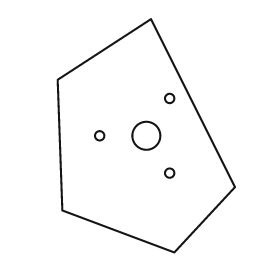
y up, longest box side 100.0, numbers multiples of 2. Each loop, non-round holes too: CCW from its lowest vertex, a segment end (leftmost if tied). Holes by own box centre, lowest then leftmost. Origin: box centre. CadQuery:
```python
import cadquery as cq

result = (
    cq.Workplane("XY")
    .moveTo(12.0, -50.0)
    .lineTo(38.0, -22.0)
    .lineTo(2.0, 50.0)
    .lineTo(-38.0, 24.0)
    .lineTo(-36.0, -32.0)
    .close()
    .moveTo(10.0, -16.0)
    .circle(2.0)
    .moveTo(-20.0, 0.0)
    .circle(2.0)
    .moveTo(0.0, 0.0)
    .circle(6.0)
    .moveTo(10.0, 16.0)
    .circle(2.0)
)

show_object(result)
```